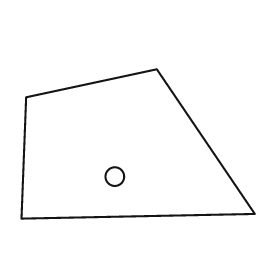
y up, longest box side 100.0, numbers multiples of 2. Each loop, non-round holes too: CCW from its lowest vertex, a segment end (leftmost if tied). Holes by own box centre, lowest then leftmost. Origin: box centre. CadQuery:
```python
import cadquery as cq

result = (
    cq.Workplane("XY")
    .moveTo(-50.0, -32.0)
    .lineTo(50.0, -30.0)
    .lineTo(8.0, 32.0)
    .lineTo(-48.0, 20.0)
    .close()
    .moveTo(-10.0, -14.0)
    .circle(4.0)
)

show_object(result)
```